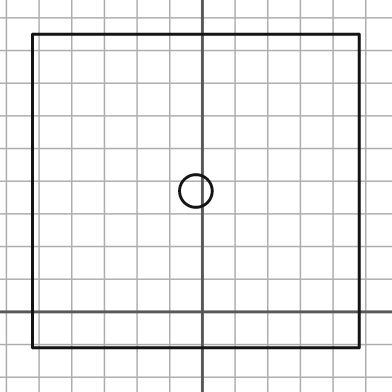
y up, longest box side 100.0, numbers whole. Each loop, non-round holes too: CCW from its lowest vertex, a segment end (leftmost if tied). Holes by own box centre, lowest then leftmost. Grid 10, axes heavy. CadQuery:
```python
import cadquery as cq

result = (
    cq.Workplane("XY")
    .moveTo(-52.0, -11.0)
    .lineTo(48.0, -11.0)
    .lineTo(48.0, 85.0)
    .lineTo(-52.0, 85.0)
    .close()
    .moveTo(-2.0, 37.0)
    .circle(5.0)
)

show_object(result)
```